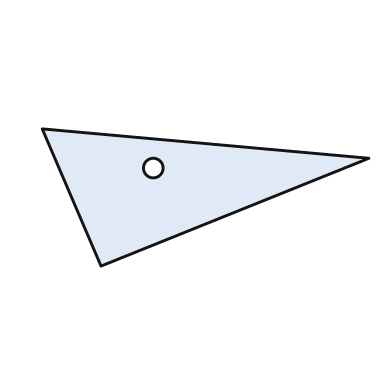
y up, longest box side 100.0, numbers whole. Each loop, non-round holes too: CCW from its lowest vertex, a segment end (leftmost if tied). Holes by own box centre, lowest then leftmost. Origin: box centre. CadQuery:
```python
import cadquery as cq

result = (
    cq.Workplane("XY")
    .moveTo(-32.0, -21.0)
    .lineTo(50.0, 12.0)
    .lineTo(-50.0, 21.0)
    .close()
    .moveTo(-16.0, 9.0)
    .circle(3.0)
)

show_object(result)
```